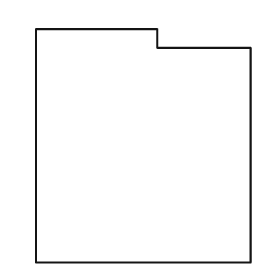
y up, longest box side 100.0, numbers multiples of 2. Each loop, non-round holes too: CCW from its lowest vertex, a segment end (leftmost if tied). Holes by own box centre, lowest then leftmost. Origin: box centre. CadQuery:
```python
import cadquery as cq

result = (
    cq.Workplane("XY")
    .moveTo(-46.0, -50.0)
    .lineTo(46.0, -50.0)
    .lineTo(46.0, 42.0)
    .lineTo(6.0, 42.0)
    .lineTo(6.0, 50.0)
    .lineTo(-46.0, 50.0)
    .close()
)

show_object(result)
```